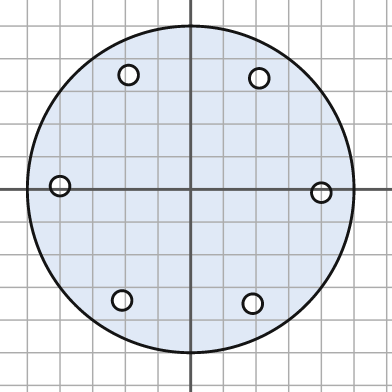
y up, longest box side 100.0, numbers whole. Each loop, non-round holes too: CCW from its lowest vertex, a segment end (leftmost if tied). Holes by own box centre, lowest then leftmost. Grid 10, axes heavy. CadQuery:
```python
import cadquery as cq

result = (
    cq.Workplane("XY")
    .moveTo(0.0, 0.0)
    .circle(50.0)
    .moveTo(19.0, -35.0)
    .circle(3.0)
    .moveTo(-21.0, -34.0)
    .circle(3.0)
    .moveTo(40.0, -1.0)
    .circle(3.0)
    .moveTo(-40.0, 1.0)
    .circle(3.0)
    .moveTo(21.0, 34.0)
    .circle(3.0)
    .moveTo(-19.0, 35.0)
    .circle(3.0)
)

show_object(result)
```